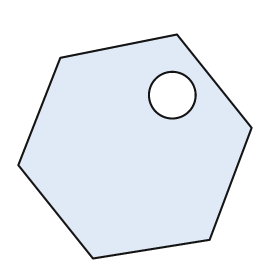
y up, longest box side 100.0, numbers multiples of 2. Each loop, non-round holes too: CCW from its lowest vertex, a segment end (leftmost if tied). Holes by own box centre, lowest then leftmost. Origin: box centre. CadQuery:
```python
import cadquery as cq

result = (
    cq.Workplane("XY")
    .moveTo(-18.0, -48.0)
    .lineTo(32.0, -40.0)
    .lineTo(50.0, 8.0)
    .lineTo(18.0, 48.0)
    .lineTo(-32.0, 38.0)
    .lineTo(-50.0, -8.0)
    .close()
    .moveTo(16.0, 22.0)
    .circle(10.0)
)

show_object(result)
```